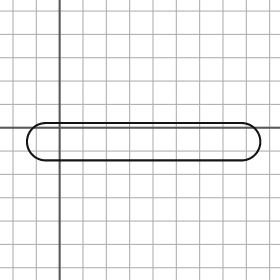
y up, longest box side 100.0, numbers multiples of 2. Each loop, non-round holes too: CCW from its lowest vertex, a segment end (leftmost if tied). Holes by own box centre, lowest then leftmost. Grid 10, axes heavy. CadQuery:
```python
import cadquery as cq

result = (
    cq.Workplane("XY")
    .moveTo(-6.0, -14.0)
    .lineTo(78.0, -14.0)
    .threePointArc((86.0, -6.0), (78.0, 2.0))
    .lineTo(-6.0, 2.0)
    .threePointArc((-14.0, -6.0), (-6.0, -14.0))
    .close()
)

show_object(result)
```